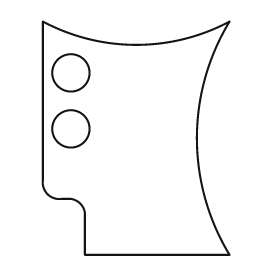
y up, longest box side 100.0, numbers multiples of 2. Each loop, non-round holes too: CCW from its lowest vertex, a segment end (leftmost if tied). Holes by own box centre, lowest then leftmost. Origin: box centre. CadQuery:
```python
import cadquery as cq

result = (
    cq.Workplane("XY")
    .moveTo(-22.0, -50.0)
    .lineTo(40.0, -50.0)
    .threePointArc((26.0, 0.0), (40.0, 50.0))
    .threePointArc((0.0, 40.0), (-40.0, 50.0))
    .lineTo(-40.0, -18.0)
    .threePointArc((-38.0, -24.0), (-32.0, -26.0))
    .lineTo(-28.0, -26.0)
    .threePointArc((-24.0, -28.0), (-22.0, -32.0))
    .close()
    .moveTo(-28.0, 4.0)
    .circle(8.0)
    .moveTo(-28.0, 28.0)
    .circle(8.0)
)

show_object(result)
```